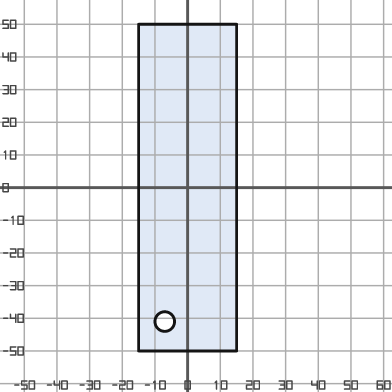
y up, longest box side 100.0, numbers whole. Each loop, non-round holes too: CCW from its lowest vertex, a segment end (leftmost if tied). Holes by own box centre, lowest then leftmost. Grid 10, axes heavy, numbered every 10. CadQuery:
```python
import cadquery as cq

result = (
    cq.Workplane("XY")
    .moveTo(-15.0, -50.0)
    .lineTo(15.0, -50.0)
    .lineTo(15.0, 50.0)
    .lineTo(-15.0, 50.0)
    .close()
    .moveTo(-7.0, -41.0)
    .circle(3.0)
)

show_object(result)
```